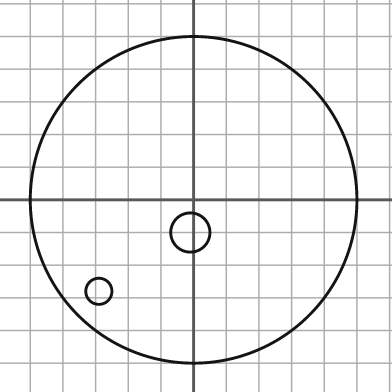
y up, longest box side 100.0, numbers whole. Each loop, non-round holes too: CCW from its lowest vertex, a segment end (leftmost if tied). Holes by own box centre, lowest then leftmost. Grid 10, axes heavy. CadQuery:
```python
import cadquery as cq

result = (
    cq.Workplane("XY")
    .moveTo(0.0, 0.0)
    .circle(50.0)
    .moveTo(-29.0, -28.0)
    .circle(4.0)
    .moveTo(-1.0, -10.0)
    .circle(6.0)
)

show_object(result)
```